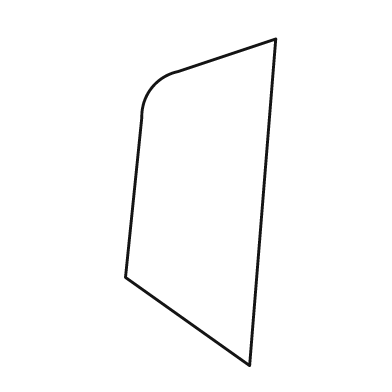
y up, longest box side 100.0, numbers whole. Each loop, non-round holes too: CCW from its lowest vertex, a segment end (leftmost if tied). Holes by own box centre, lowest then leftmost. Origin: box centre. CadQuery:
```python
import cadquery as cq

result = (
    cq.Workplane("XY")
    .moveTo(15.0, -50.0)
    .lineTo(23.0, 50.0)
    .lineTo(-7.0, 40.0)
    .threePointArc((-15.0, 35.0), (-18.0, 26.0))
    .lineTo(-23.0, -23.0)
    .close()
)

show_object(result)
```